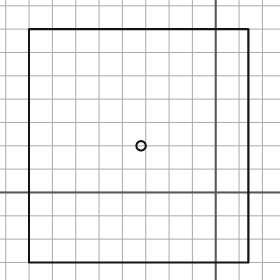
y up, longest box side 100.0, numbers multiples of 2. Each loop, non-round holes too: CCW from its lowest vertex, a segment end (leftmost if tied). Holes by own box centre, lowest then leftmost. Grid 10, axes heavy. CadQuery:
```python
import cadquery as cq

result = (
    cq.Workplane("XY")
    .moveTo(-80.0, -30.0)
    .lineTo(14.0, -30.0)
    .lineTo(14.0, 70.0)
    .lineTo(-80.0, 70.0)
    .close()
    .moveTo(-32.0, 20.0)
    .circle(2.0)
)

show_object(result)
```